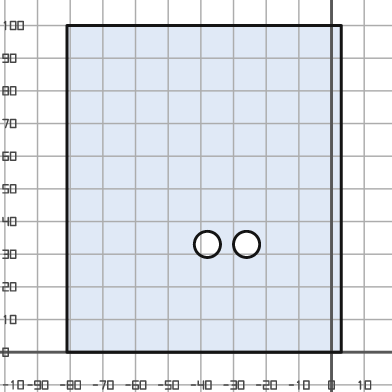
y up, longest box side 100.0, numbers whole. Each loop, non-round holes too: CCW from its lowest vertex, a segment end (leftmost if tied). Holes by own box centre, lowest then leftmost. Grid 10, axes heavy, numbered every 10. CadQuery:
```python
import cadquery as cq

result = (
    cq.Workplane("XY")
    .moveTo(-81.0, 0.0)
    .lineTo(3.0, 0.0)
    .lineTo(3.0, 100.0)
    .lineTo(-81.0, 100.0)
    .close()
    .moveTo(-38.0, 33.0)
    .circle(4.0)
    .moveTo(-26.0, 33.0)
    .circle(4.0)
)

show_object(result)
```